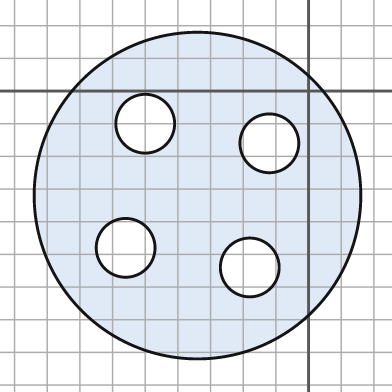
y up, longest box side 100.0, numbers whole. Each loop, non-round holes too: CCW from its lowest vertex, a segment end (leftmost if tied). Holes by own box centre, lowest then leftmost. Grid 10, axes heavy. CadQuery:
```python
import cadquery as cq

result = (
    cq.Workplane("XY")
    .moveTo(-34.0, -32.0)
    .circle(50.0)
    .moveTo(-18.0, -54.0)
    .circle(9.0)
    .moveTo(-56.0, -48.0)
    .circle(9.0)
    .moveTo(-12.0, -16.0)
    .circle(9.0)
    .moveTo(-50.0, -10.0)
    .circle(9.0)
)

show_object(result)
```